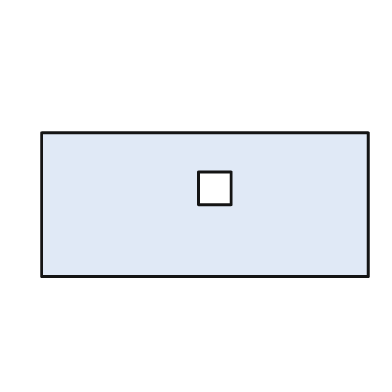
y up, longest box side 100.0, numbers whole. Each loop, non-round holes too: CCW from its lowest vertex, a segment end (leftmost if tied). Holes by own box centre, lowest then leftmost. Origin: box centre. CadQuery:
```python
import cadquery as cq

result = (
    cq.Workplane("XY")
    .moveTo(-50.0, -22.0)
    .lineTo(50.0, -22.0)
    .lineTo(50.0, 22.0)
    .lineTo(-50.0, 22.0)
    .close()
    .moveTo(-2.0, 0.0)
    .lineTo(8.0, 0.0)
    .lineTo(8.0, 10.0)
    .lineTo(-2.0, 10.0)
    .close()
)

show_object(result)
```